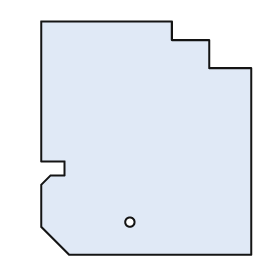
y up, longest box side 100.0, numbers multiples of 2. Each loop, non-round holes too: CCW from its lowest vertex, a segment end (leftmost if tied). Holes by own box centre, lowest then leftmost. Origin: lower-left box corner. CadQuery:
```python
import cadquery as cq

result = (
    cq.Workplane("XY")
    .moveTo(12.0, 0.0)
    .lineTo(90.0, 0.0)
    .lineTo(90.0, 80.0)
    .lineTo(72.0, 80.0)
    .lineTo(72.0, 92.0)
    .lineTo(56.0, 92.0)
    .lineTo(56.0, 100.0)
    .lineTo(0.0, 100.0)
    .lineTo(0.0, 40.0)
    .lineTo(10.0, 40.0)
    .lineTo(10.0, 34.0)
    .lineTo(4.0, 34.0)
    .lineTo(0.0, 30.0)
    .lineTo(0.0, 12.0)
    .close()
    .moveTo(38.0, 14.0)
    .circle(2.0)
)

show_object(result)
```